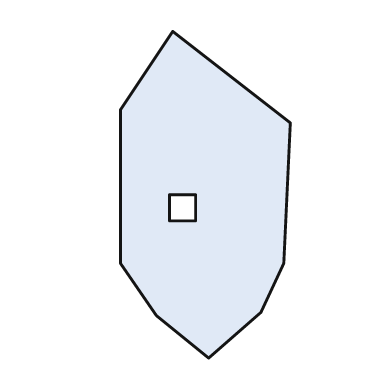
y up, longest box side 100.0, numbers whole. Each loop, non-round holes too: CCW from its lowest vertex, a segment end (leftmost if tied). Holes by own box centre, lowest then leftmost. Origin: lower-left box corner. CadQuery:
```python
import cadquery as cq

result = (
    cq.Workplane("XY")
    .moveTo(27.0, 0.0)
    .lineTo(43.0, 14.0)
    .lineTo(50.0, 29.0)
    .lineTo(52.0, 72.0)
    .lineTo(16.0, 100.0)
    .lineTo(0.0, 76.0)
    .lineTo(0.0, 29.0)
    .lineTo(11.0, 13.0)
    .close()
    .moveTo(15.0, 42.0)
    .lineTo(23.0, 42.0)
    .lineTo(23.0, 50.0)
    .lineTo(15.0, 50.0)
    .close()
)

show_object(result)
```